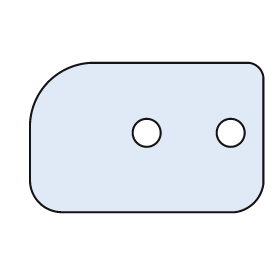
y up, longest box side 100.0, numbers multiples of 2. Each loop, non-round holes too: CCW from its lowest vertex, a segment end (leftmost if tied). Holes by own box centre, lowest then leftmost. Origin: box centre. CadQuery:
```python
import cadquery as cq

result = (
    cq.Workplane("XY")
    .moveTo(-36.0, -32.0)
    .lineTo(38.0, -32.0)
    .threePointArc((46.0, -28.0), (50.0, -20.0))
    .lineTo(50.0, 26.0)
    .threePointArc((48.0, 30.0), (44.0, 32.0))
    .lineTo(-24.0, 32.0)
    .threePointArc((-42.0, 24.0), (-50.0, 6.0))
    .lineTo(-50.0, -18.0)
    .threePointArc((-46.0, -28.0), (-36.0, -32.0))
    .close()
    .moveTo(0.0, 2.0)
    .circle(6.0)
    .moveTo(36.0, 2.0)
    .circle(6.0)
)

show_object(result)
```